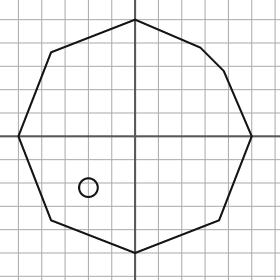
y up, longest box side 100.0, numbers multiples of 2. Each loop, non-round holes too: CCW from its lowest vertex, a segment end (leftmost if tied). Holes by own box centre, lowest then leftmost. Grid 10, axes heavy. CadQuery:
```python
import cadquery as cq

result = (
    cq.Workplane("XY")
    .moveTo(0.0, -50.0)
    .lineTo(36.0, -36.0)
    .lineTo(50.0, 0.0)
    .lineTo(38.0, 28.0)
    .lineTo(28.0, 38.0)
    .lineTo(0.0, 50.0)
    .lineTo(-36.0, 36.0)
    .lineTo(-50.0, 0.0)
    .lineTo(-36.0, -36.0)
    .close()
    .moveTo(-20.0, -22.0)
    .circle(4.0)
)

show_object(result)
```